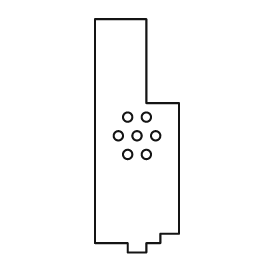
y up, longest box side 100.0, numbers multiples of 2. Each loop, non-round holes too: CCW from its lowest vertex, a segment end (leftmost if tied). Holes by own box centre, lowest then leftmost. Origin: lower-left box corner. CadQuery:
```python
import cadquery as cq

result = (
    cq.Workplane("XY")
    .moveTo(14.0, 0.0)
    .lineTo(22.0, 0.0)
    .lineTo(22.0, 4.0)
    .lineTo(28.0, 4.0)
    .lineTo(28.0, 8.0)
    .lineTo(36.0, 8.0)
    .lineTo(36.0, 64.0)
    .lineTo(22.0, 64.0)
    .lineTo(22.0, 100.0)
    .lineTo(0.0, 100.0)
    .lineTo(0.0, 4.0)
    .lineTo(14.0, 4.0)
    .close()
    .moveTo(14.0, 42.0)
    .circle(2.0)
    .moveTo(22.0, 42.0)
    .circle(2.0)
    .moveTo(10.0, 50.0)
    .circle(2.0)
    .moveTo(18.0, 50.0)
    .circle(2.0)
    .moveTo(26.0, 50.0)
    .circle(2.0)
    .moveTo(14.0, 58.0)
    .circle(2.0)
    .moveTo(22.0, 58.0)
    .circle(2.0)
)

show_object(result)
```